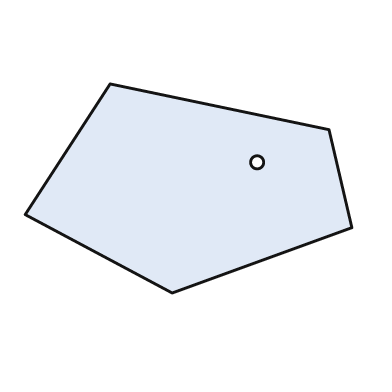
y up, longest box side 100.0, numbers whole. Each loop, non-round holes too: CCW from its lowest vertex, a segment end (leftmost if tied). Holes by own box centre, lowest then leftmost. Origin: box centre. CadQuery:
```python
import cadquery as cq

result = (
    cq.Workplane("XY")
    .moveTo(-5.0, -32.0)
    .lineTo(50.0, -12.0)
    .lineTo(43.0, 18.0)
    .lineTo(-24.0, 32.0)
    .lineTo(-50.0, -8.0)
    .close()
    .moveTo(21.0, 8.0)
    .circle(2.0)
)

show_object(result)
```